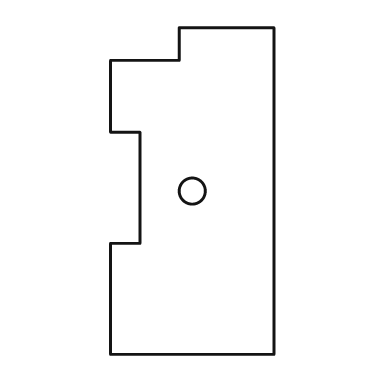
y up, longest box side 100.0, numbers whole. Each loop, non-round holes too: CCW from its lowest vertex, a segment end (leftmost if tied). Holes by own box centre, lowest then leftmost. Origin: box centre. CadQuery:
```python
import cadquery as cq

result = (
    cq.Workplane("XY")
    .moveTo(-25.0, -50.0)
    .lineTo(25.0, -50.0)
    .lineTo(25.0, 50.0)
    .lineTo(-4.0, 50.0)
    .lineTo(-4.0, 40.0)
    .lineTo(-25.0, 40.0)
    .lineTo(-25.0, 18.0)
    .lineTo(-16.0, 18.0)
    .lineTo(-16.0, -16.0)
    .lineTo(-25.0, -16.0)
    .close()
    .moveTo(0.0, 0.0)
    .circle(4.0)
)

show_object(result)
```